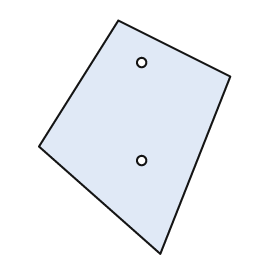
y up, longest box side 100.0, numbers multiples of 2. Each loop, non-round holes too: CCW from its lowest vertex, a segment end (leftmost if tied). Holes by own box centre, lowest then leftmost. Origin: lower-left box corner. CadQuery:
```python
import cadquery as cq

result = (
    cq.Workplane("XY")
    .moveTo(52.0, 0.0)
    .lineTo(82.0, 76.0)
    .lineTo(34.0, 100.0)
    .lineTo(0.0, 46.0)
    .close()
    .moveTo(44.0, 40.0)
    .circle(2.0)
    .moveTo(44.0, 82.0)
    .circle(2.0)
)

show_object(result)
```